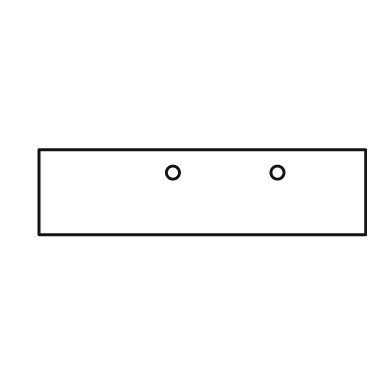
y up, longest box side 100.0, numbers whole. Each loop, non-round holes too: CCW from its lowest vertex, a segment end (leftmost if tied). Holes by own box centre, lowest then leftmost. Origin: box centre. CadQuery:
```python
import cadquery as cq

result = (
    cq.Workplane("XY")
    .moveTo(-50.0, -13.0)
    .lineTo(50.0, -13.0)
    .lineTo(50.0, 13.0)
    .lineTo(-50.0, 13.0)
    .close()
    .moveTo(-9.0, 6.0)
    .circle(2.0)
    .moveTo(23.0, 6.0)
    .circle(2.0)
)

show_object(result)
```